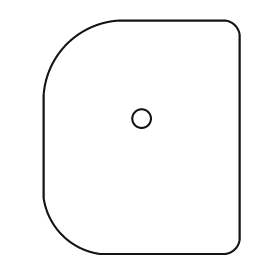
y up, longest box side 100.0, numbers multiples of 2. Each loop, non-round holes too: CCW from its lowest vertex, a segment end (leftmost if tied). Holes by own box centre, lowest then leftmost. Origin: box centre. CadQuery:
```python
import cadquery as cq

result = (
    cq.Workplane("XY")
    .moveTo(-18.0, -50.0)
    .lineTo(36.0, -50.0)
    .threePointArc((40.0, -48.0), (42.0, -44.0))
    .lineTo(42.0, 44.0)
    .threePointArc((40.0, 48.0), (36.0, 50.0))
    .lineTo(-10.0, 50.0)
    .threePointArc((-32.0, 40.0), (-42.0, 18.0))
    .lineTo(-42.0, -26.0)
    .threePointArc((-34.0, -42.0), (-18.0, -50.0))
    .close()
    .moveTo(0.0, 8.0)
    .circle(4.0)
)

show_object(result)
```